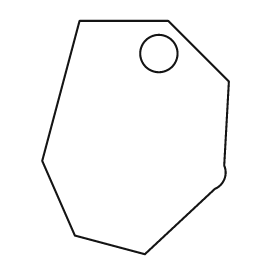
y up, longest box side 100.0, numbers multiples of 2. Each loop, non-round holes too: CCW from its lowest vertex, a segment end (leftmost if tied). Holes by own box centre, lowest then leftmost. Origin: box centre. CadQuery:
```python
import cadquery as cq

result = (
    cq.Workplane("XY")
    .moveTo(4.0, -50.0)
    .lineTo(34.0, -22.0)
    .threePointArc((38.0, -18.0), (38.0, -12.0))
    .lineTo(40.0, 24.0)
    .lineTo(14.0, 50.0)
    .lineTo(-24.0, 50.0)
    .lineTo(-40.0, -10.0)
    .lineTo(-26.0, -42.0)
    .close()
    .moveTo(10.0, 36.0)
    .circle(8.0)
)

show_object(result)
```